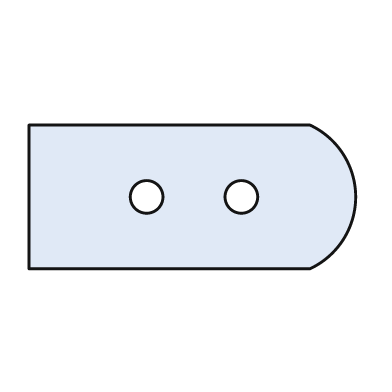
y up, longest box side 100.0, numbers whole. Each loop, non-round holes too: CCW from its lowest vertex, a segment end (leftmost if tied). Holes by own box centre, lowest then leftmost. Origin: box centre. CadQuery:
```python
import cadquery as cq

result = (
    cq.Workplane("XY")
    .moveTo(-50.0, -22.0)
    .lineTo(36.0, -22.0)
    .threePointArc((50.0, 0.0), (36.0, 22.0))
    .lineTo(-50.0, 22.0)
    .close()
    .moveTo(-14.0, 0.0)
    .circle(5.0)
    .moveTo(15.0, 0.0)
    .circle(5.0)
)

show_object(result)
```